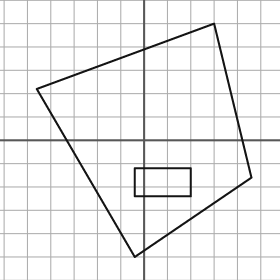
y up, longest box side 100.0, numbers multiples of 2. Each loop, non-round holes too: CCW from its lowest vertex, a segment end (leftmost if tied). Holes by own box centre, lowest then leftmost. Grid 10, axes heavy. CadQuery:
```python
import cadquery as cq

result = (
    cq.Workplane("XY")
    .moveTo(-4.0, -50.0)
    .lineTo(46.0, -16.0)
    .lineTo(30.0, 50.0)
    .lineTo(-46.0, 22.0)
    .close()
    .moveTo(-4.0, -24.0)
    .lineTo(20.0, -24.0)
    .lineTo(20.0, -12.0)
    .lineTo(-4.0, -12.0)
    .close()
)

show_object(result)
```